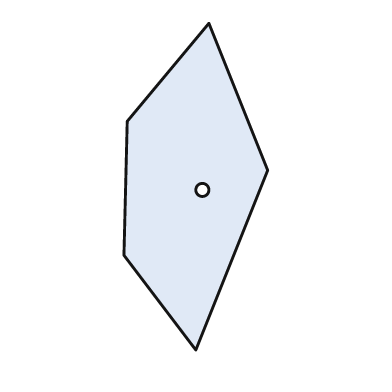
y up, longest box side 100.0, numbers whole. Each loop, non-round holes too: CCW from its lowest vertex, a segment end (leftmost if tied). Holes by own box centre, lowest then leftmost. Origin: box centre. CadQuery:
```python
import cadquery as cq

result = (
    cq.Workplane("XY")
    .moveTo(0.0, -50.0)
    .lineTo(22.0, 5.0)
    .lineTo(4.0, 50.0)
    .lineTo(-21.0, 20.0)
    .lineTo(-22.0, -21.0)
    .close()
    .moveTo(2.0, -1.0)
    .circle(2.0)
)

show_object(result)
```